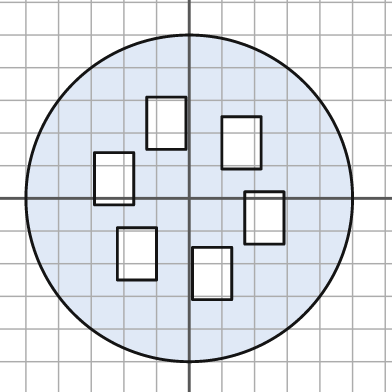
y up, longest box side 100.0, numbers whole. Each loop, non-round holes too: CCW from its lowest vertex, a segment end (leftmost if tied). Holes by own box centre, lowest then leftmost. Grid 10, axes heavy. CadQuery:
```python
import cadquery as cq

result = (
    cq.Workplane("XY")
    .moveTo(0.0, 0.0)
    .circle(50.0)
    .moveTo(1.0, -31.0)
    .lineTo(13.0, -31.0)
    .lineTo(13.0, -15.0)
    .lineTo(1.0, -15.0)
    .close()
    .moveTo(-22.0, -25.0)
    .lineTo(-10.0, -25.0)
    .lineTo(-10.0, -9.0)
    .lineTo(-22.0, -9.0)
    .close()
    .moveTo(17.0, -14.0)
    .lineTo(29.0, -14.0)
    .lineTo(29.0, 2.0)
    .lineTo(17.0, 2.0)
    .close()
    .moveTo(-29.0, -2.0)
    .lineTo(-17.0, -2.0)
    .lineTo(-17.0, 14.0)
    .lineTo(-29.0, 14.0)
    .close()
    .moveTo(10.0, 9.0)
    .lineTo(22.0, 9.0)
    .lineTo(22.0, 25.0)
    .lineTo(10.0, 25.0)
    .close()
    .moveTo(-13.0, 15.0)
    .lineTo(-1.0, 15.0)
    .lineTo(-1.0, 31.0)
    .lineTo(-13.0, 31.0)
    .close()
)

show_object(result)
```